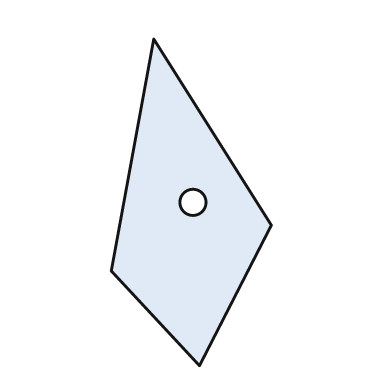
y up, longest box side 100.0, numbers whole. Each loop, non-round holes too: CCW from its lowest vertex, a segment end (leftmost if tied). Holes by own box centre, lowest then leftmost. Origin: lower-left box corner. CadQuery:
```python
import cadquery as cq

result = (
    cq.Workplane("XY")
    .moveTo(27.0, 0.0)
    .lineTo(49.0, 43.0)
    .lineTo(13.0, 100.0)
    .lineTo(0.0, 29.0)
    .close()
    .moveTo(25.0, 50.0)
    .circle(4.0)
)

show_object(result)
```